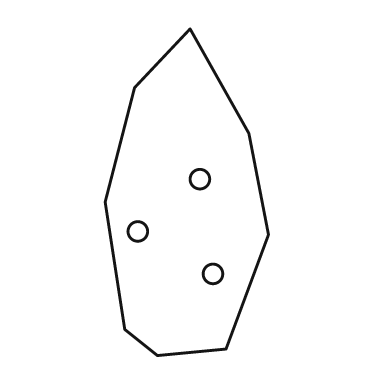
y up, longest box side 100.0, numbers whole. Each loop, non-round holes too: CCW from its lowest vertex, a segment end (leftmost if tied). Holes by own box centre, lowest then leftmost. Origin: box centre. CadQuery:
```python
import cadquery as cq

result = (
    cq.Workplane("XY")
    .moveTo(-9.0, -50.0)
    .lineTo(12.0, -48.0)
    .lineTo(25.0, -13.0)
    .lineTo(19.0, 18.0)
    .lineTo(1.0, 50.0)
    .lineTo(-16.0, 32.0)
    .lineTo(-25.0, -3.0)
    .lineTo(-19.0, -42.0)
    .close()
    .moveTo(8.0, -25.0)
    .circle(3.0)
    .moveTo(-15.0, -12.0)
    .circle(3.0)
    .moveTo(4.0, 4.0)
    .circle(3.0)
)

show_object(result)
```